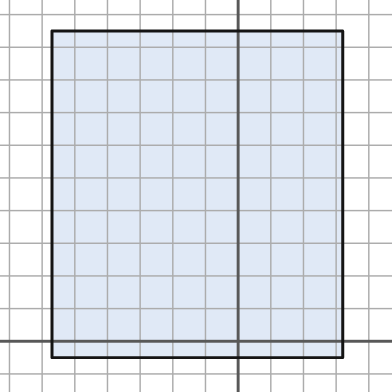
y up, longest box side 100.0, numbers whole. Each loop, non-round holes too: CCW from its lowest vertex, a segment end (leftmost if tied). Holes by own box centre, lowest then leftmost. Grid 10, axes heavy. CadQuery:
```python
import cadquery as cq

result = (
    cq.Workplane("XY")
    .moveTo(-57.0, -5.0)
    .lineTo(32.0, -5.0)
    .lineTo(32.0, 95.0)
    .lineTo(-57.0, 95.0)
    .close()
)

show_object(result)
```